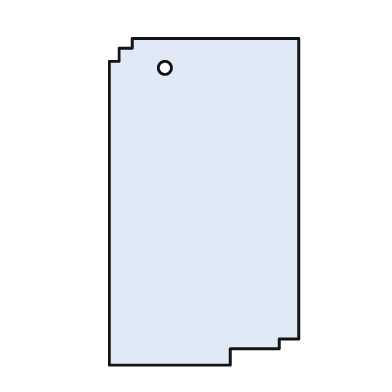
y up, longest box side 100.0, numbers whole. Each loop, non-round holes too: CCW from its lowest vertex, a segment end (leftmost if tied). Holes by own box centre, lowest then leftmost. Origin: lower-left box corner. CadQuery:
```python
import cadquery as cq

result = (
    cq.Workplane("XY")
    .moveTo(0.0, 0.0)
    .lineTo(37.0, 0.0)
    .lineTo(37.0, 5.0)
    .lineTo(52.0, 5.0)
    .lineTo(52.0, 8.0)
    .lineTo(58.0, 8.0)
    .lineTo(58.0, 100.0)
    .lineTo(7.0, 100.0)
    .lineTo(7.0, 97.0)
    .lineTo(3.0, 97.0)
    .lineTo(3.0, 93.0)
    .lineTo(0.0, 93.0)
    .close()
    .moveTo(17.0, 91.0)
    .circle(2.0)
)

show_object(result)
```